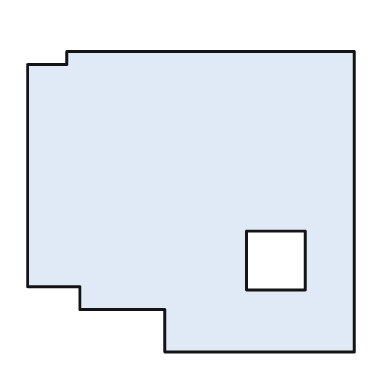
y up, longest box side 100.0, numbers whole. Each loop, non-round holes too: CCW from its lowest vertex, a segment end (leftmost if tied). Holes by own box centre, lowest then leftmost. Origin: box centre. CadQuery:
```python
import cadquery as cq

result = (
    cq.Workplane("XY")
    .moveTo(-8.0, -46.0)
    .lineTo(50.0, -46.0)
    .lineTo(50.0, 46.0)
    .lineTo(-38.0, 46.0)
    .lineTo(-38.0, 42.0)
    .lineTo(-50.0, 42.0)
    .lineTo(-50.0, -26.0)
    .lineTo(-34.0, -26.0)
    .lineTo(-34.0, -33.0)
    .lineTo(-8.0, -33.0)
    .close()
    .moveTo(17.0, -27.0)
    .lineTo(35.0, -27.0)
    .lineTo(35.0, -9.0)
    .lineTo(17.0, -9.0)
    .close()
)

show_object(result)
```